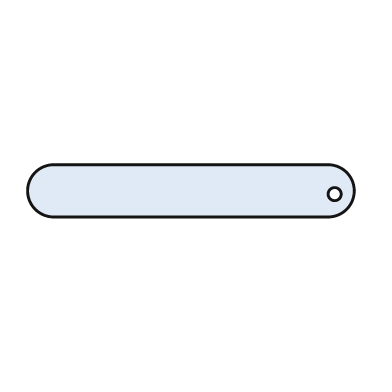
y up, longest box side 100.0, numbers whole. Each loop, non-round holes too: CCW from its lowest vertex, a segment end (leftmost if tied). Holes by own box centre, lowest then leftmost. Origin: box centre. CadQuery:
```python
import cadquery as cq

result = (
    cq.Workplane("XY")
    .moveTo(-42.0, -8.0)
    .lineTo(42.0, -8.0)
    .threePointArc((50.0, 0.0), (42.0, 8.0))
    .lineTo(-42.0, 8.0)
    .threePointArc((-50.0, 0.0), (-42.0, -8.0))
    .close()
    .moveTo(44.0, -1.0)
    .circle(2.0)
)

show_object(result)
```